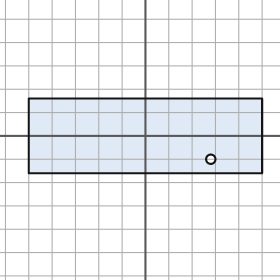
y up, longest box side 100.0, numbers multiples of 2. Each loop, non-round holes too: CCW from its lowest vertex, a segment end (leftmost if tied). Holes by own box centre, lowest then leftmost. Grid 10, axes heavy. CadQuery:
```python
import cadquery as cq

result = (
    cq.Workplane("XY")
    .moveTo(-50.0, -16.0)
    .lineTo(50.0, -16.0)
    .lineTo(50.0, 16.0)
    .lineTo(-50.0, 16.0)
    .close()
    .moveTo(28.0, -10.0)
    .circle(2.0)
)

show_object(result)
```